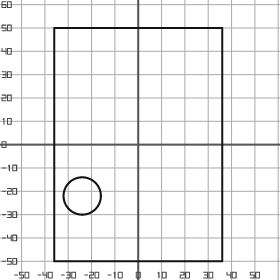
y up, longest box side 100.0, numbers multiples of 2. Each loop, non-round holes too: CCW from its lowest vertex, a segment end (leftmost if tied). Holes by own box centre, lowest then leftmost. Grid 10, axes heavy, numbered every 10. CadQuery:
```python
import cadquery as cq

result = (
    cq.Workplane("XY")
    .moveTo(-36.0, -50.0)
    .lineTo(36.0, -50.0)
    .lineTo(36.0, 50.0)
    .lineTo(-36.0, 50.0)
    .close()
    .moveTo(-24.0, -22.0)
    .circle(8.0)
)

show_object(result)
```